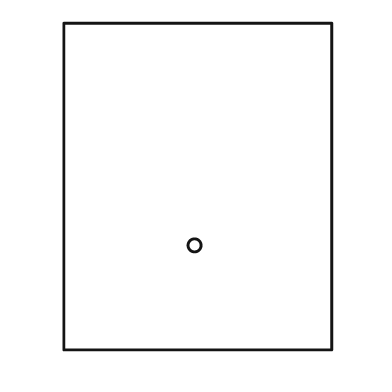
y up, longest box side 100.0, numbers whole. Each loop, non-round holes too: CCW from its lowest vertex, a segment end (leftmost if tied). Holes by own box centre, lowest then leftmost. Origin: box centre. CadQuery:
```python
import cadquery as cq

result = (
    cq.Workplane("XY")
    .moveTo(-41.0, -50.0)
    .lineTo(41.0, -50.0)
    .lineTo(41.0, 50.0)
    .lineTo(-41.0, 50.0)
    .close()
    .moveTo(-1.0, -18.0)
    .circle(2.0)
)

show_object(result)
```